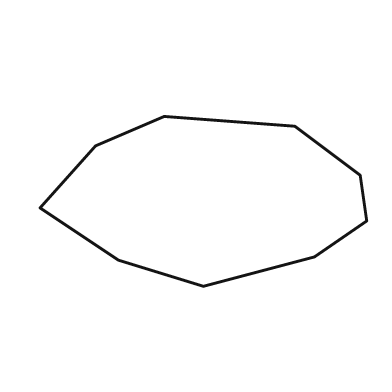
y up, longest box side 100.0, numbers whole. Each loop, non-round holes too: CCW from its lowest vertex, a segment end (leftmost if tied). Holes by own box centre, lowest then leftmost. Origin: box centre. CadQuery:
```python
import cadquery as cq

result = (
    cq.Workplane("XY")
    .moveTo(0.0, -26.0)
    .lineTo(34.0, -17.0)
    .lineTo(50.0, -6.0)
    .lineTo(48.0, 8.0)
    .lineTo(28.0, 23.0)
    .lineTo(-12.0, 26.0)
    .lineTo(-33.0, 17.0)
    .lineTo(-50.0, -2.0)
    .lineTo(-26.0, -18.0)
    .close()
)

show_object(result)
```